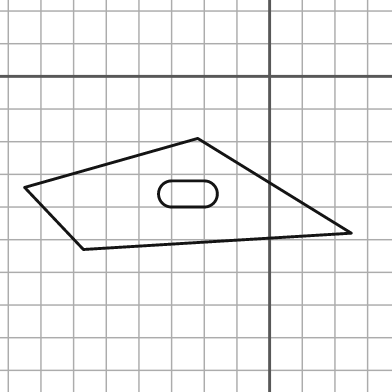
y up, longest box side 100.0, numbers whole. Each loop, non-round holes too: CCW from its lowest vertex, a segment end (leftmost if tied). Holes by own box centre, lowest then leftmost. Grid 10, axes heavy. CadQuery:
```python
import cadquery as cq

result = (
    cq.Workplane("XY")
    .moveTo(-57.0, -53.0)
    .lineTo(25.0, -48.0)
    .lineTo(-22.0, -19.0)
    .lineTo(-75.0, -34.0)
    .close()
    .moveTo(-30.0, -40.0)
    .lineTo(-20.0, -40.0)
    .threePointArc((-16.0, -36.0), (-20.0, -32.0))
    .lineTo(-30.0, -32.0)
    .threePointArc((-34.0, -36.0), (-30.0, -40.0))
    .close()
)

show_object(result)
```